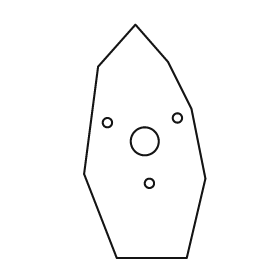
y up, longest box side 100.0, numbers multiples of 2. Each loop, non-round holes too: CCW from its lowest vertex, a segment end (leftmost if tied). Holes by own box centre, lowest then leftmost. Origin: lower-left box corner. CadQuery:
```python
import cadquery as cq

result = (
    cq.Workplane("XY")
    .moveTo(14.0, 0.0)
    .lineTo(44.0, 0.0)
    .lineTo(52.0, 34.0)
    .lineTo(46.0, 64.0)
    .lineTo(36.0, 84.0)
    .lineTo(22.0, 100.0)
    .lineTo(6.0, 82.0)
    .lineTo(0.0, 36.0)
    .close()
    .moveTo(28.0, 32.0)
    .circle(2.0)
    .moveTo(26.0, 50.0)
    .circle(6.0)
    .moveTo(10.0, 58.0)
    .circle(2.0)
    .moveTo(40.0, 60.0)
    .circle(2.0)
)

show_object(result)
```